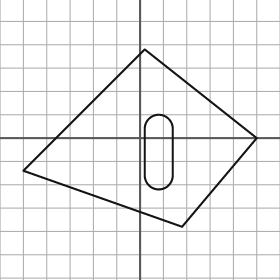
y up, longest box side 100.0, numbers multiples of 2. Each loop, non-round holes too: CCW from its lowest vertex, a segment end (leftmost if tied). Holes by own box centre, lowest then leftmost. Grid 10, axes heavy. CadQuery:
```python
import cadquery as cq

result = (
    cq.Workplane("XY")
    .moveTo(18.0, -38.0)
    .lineTo(50.0, 0.0)
    .lineTo(2.0, 38.0)
    .lineTo(-50.0, -14.0)
    .close()
    .moveTo(2.0, -16.0)
    .threePointArc((8.0, -22.0), (14.0, -16.0))
    .lineTo(14.0, 4.0)
    .threePointArc((8.0, 10.0), (2.0, 4.0))
    .close()
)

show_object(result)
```